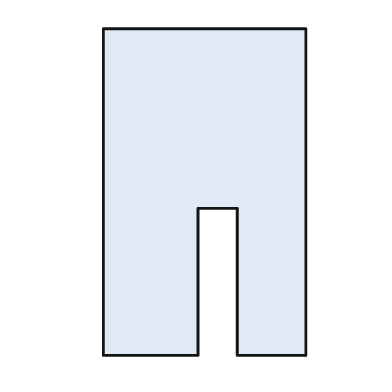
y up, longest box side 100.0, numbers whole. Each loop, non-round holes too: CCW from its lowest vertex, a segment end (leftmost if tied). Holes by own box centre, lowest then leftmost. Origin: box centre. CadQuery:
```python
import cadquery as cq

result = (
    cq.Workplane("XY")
    .moveTo(-31.0, -50.0)
    .lineTo(-2.0, -50.0)
    .lineTo(-2.0, -5.0)
    .lineTo(10.0, -5.0)
    .lineTo(10.0, -50.0)
    .lineTo(31.0, -50.0)
    .lineTo(31.0, 50.0)
    .lineTo(-31.0, 50.0)
    .close()
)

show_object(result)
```